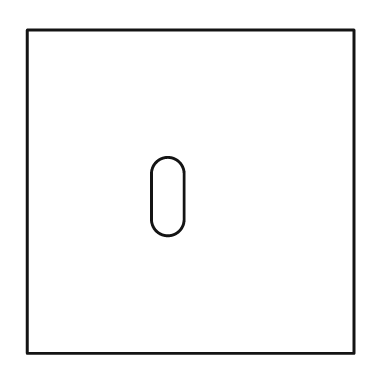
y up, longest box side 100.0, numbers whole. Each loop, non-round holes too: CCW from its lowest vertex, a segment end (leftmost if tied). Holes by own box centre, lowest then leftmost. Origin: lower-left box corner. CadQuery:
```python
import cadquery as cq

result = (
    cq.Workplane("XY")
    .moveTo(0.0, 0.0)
    .lineTo(100.0, 0.0)
    .lineTo(100.0, 99.0)
    .lineTo(0.0, 99.0)
    .close()
    .moveTo(38.0, 41.0)
    .threePointArc((43.0, 36.0), (48.0, 41.0))
    .lineTo(48.0, 55.0)
    .threePointArc((43.0, 60.0), (38.0, 55.0))
    .close()
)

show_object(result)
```